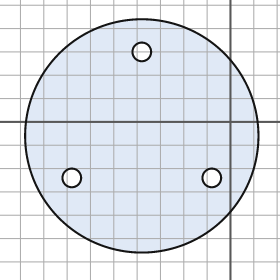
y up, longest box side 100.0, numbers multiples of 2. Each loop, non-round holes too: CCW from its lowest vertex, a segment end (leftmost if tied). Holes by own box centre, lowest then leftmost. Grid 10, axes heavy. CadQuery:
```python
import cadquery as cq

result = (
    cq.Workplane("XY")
    .moveTo(-38.0, -6.0)
    .circle(50.0)
    .moveTo(-68.0, -24.0)
    .circle(4.0)
    .moveTo(-8.0, -24.0)
    .circle(4.0)
    .moveTo(-38.0, 30.0)
    .circle(4.0)
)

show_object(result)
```